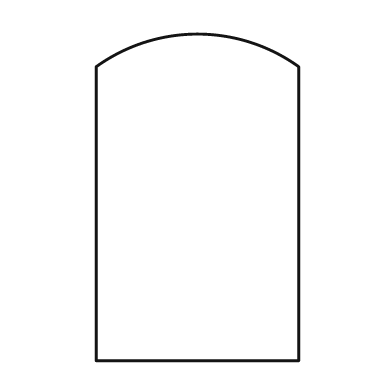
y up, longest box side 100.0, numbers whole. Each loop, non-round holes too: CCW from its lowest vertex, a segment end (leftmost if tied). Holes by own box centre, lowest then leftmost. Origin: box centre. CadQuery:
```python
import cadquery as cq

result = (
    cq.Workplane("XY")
    .moveTo(-31.0, -50.0)
    .lineTo(31.0, -50.0)
    .lineTo(31.0, 40.0)
    .threePointArc((0.0, 50.0), (-31.0, 40.0))
    .close()
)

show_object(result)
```